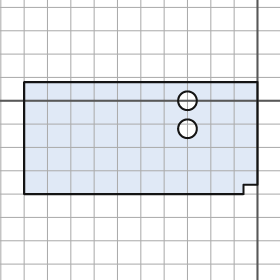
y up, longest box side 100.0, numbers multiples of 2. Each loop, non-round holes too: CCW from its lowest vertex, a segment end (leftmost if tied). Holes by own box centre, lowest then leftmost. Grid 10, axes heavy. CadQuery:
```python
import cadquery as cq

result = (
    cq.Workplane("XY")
    .moveTo(-100.0, -40.0)
    .lineTo(-6.0, -40.0)
    .lineTo(-6.0, -36.0)
    .lineTo(0.0, -36.0)
    .lineTo(0.0, 8.0)
    .lineTo(-100.0, 8.0)
    .close()
    .moveTo(-30.0, -12.0)
    .circle(4.0)
    .moveTo(-30.0, 0.0)
    .circle(4.0)
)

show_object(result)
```